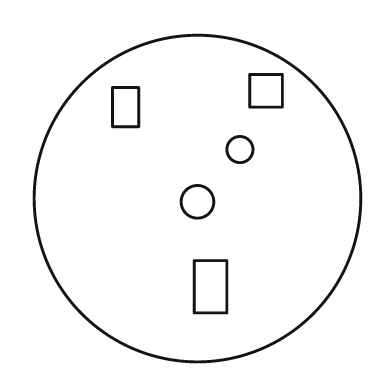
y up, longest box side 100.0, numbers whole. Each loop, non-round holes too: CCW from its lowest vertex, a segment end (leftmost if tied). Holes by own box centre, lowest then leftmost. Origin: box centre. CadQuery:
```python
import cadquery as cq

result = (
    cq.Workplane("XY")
    .moveTo(0.0, 0.0)
    .circle(50.0)
    .moveTo(-1.0, -35.0)
    .lineTo(9.0, -35.0)
    .lineTo(9.0, -19.0)
    .lineTo(-1.0, -19.0)
    .close()
    .moveTo(0.0, -1.0)
    .circle(5.0)
    .moveTo(13.0, 15.0)
    .circle(4.0)
    .moveTo(-26.0, 22.0)
    .lineTo(-18.0, 22.0)
    .lineTo(-18.0, 34.0)
    .lineTo(-26.0, 34.0)
    .close()
    .moveTo(16.0, 28.0)
    .lineTo(26.0, 28.0)
    .lineTo(26.0, 38.0)
    .lineTo(16.0, 38.0)
    .close()
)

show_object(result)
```